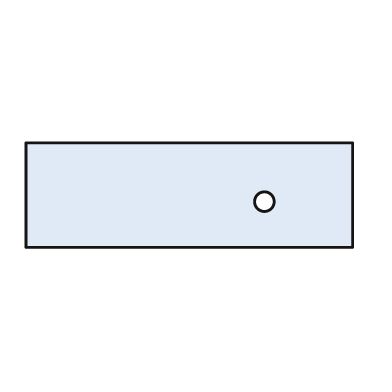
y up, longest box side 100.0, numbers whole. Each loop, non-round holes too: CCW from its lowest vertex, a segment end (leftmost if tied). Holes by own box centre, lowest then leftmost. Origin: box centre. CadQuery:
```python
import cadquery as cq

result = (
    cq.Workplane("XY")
    .moveTo(-50.0, -16.0)
    .lineTo(50.0, -16.0)
    .lineTo(50.0, 16.0)
    .lineTo(-50.0, 16.0)
    .close()
    .moveTo(23.0, -2.0)
    .circle(3.0)
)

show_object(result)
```